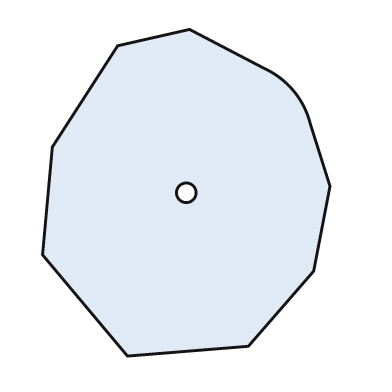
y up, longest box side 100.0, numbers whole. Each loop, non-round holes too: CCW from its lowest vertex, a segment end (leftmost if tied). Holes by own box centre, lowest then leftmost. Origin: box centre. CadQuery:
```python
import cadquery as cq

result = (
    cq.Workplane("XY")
    .moveTo(-18.0, -50.0)
    .lineTo(19.0, -47.0)
    .lineTo(39.0, -24.0)
    .lineTo(44.0, 2.0)
    .lineTo(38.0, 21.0)
    .threePointArc((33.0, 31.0), (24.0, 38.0))
    .lineTo(1.0, 50.0)
    .lineTo(-21.0, 45.0)
    .lineTo(-41.0, 14.0)
    .lineTo(-44.0, -19.0)
    .close()
    .moveTo(0.0, 0.0)
    .circle(3.0)
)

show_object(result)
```